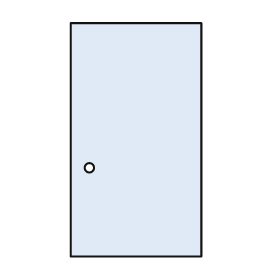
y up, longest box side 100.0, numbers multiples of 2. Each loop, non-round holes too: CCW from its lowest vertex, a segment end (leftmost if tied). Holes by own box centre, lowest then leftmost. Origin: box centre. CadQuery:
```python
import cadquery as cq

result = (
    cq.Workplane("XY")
    .moveTo(-28.0, -50.0)
    .lineTo(28.0, -50.0)
    .lineTo(28.0, 50.0)
    .lineTo(-28.0, 50.0)
    .close()
    .moveTo(-20.0, -12.0)
    .circle(2.0)
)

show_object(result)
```